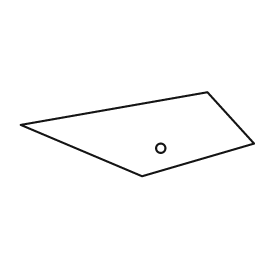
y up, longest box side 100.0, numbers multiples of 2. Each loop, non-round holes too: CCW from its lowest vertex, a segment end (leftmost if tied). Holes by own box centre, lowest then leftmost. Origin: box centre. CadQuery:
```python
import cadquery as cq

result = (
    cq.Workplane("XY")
    .moveTo(2.0, -18.0)
    .lineTo(50.0, -4.0)
    .lineTo(30.0, 18.0)
    .lineTo(-50.0, 4.0)
    .close()
    .moveTo(10.0, -6.0)
    .circle(2.0)
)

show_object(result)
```